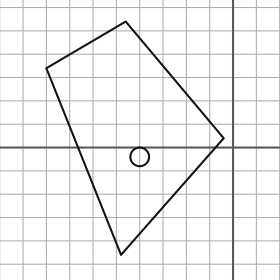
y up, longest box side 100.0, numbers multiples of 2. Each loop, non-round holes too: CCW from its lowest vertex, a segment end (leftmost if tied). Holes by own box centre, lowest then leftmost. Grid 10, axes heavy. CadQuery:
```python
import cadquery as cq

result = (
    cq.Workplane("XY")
    .moveTo(-48.0, -46.0)
    .lineTo(-4.0, 4.0)
    .lineTo(-46.0, 54.0)
    .lineTo(-80.0, 34.0)
    .close()
    .moveTo(-40.0, -4.0)
    .circle(4.0)
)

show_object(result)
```